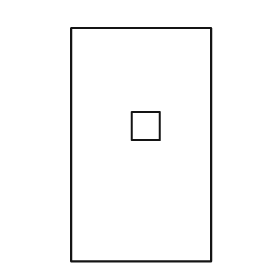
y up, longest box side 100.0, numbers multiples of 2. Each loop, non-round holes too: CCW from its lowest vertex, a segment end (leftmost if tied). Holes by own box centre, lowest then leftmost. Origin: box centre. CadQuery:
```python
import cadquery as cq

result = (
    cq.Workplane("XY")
    .moveTo(-30.0, -50.0)
    .lineTo(30.0, -50.0)
    .lineTo(30.0, 50.0)
    .lineTo(-30.0, 50.0)
    .close()
    .moveTo(-4.0, 2.0)
    .lineTo(8.0, 2.0)
    .lineTo(8.0, 14.0)
    .lineTo(-4.0, 14.0)
    .close()
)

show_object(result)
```